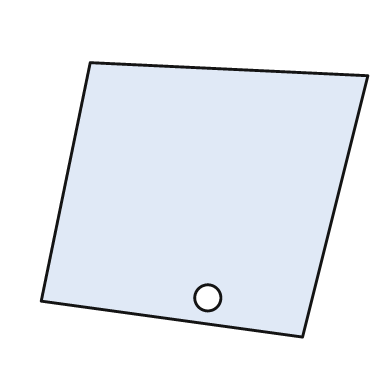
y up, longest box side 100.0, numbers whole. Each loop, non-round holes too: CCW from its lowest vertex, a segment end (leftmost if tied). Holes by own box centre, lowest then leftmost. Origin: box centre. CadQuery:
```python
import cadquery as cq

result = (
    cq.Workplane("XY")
    .moveTo(30.0, -42.0)
    .lineTo(50.0, 38.0)
    .lineTo(-35.0, 42.0)
    .lineTo(-50.0, -31.0)
    .close()
    .moveTo(1.0, -30.0)
    .circle(4.0)
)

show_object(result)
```